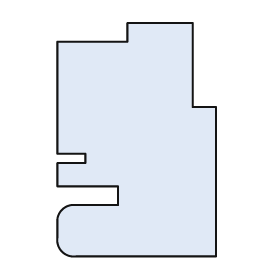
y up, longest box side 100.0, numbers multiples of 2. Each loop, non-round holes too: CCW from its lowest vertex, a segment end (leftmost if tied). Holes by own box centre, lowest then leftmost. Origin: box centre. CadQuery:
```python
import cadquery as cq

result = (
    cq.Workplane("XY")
    .moveTo(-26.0, -50.0)
    .lineTo(34.0, -50.0)
    .lineTo(34.0, 14.0)
    .lineTo(24.0, 14.0)
    .lineTo(24.0, 50.0)
    .lineTo(-4.0, 50.0)
    .lineTo(-4.0, 42.0)
    .lineTo(-34.0, 42.0)
    .lineTo(-34.0, -6.0)
    .lineTo(-22.0, -6.0)
    .lineTo(-22.0, -10.0)
    .lineTo(-34.0, -10.0)
    .lineTo(-34.0, -20.0)
    .lineTo(-8.0, -20.0)
    .lineTo(-8.0, -28.0)
    .lineTo(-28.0, -28.0)
    .threePointArc((-32.0, -30.0), (-34.0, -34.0))
    .lineTo(-34.0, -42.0)
    .threePointArc((-32.0, -48.0), (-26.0, -50.0))
    .close()
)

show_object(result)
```